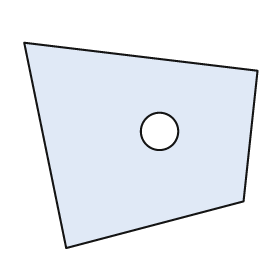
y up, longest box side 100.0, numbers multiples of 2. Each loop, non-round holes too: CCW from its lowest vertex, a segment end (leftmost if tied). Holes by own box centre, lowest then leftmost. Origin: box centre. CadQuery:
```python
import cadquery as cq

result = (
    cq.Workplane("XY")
    .moveTo(-32.0, -44.0)
    .lineTo(44.0, -24.0)
    .lineTo(50.0, 32.0)
    .lineTo(-50.0, 44.0)
    .close()
    .moveTo(8.0, 6.0)
    .circle(8.0)
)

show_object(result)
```